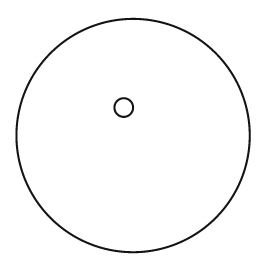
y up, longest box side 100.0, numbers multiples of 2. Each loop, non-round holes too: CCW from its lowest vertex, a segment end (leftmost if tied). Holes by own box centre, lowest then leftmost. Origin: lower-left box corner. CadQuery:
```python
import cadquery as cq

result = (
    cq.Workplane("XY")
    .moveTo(50.0, 50.0)
    .circle(50.0)
    .moveTo(46.0, 62.0)
    .circle(4.0)
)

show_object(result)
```